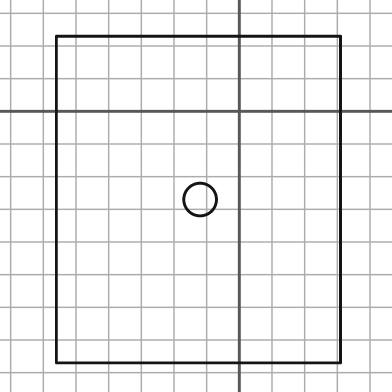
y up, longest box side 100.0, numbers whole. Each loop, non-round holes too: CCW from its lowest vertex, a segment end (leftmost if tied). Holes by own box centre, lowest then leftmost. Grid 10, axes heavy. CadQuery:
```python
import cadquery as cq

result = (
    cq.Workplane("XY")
    .moveTo(-56.0, -77.0)
    .lineTo(31.0, -77.0)
    .lineTo(31.0, 23.0)
    .lineTo(-56.0, 23.0)
    .close()
    .moveTo(-12.0, -27.0)
    .circle(5.0)
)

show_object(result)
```